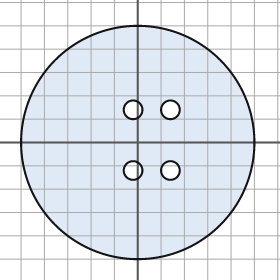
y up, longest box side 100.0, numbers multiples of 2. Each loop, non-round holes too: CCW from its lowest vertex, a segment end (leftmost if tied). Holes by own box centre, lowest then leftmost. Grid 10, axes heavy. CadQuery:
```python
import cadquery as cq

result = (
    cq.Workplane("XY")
    .moveTo(0.0, 0.0)
    .circle(50.0)
    .moveTo(-2.0, -12.0)
    .circle(4.0)
    .moveTo(14.0, -12.0)
    .circle(4.0)
    .moveTo(-2.0, 14.0)
    .circle(4.0)
    .moveTo(14.0, 14.0)
    .circle(4.0)
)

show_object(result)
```